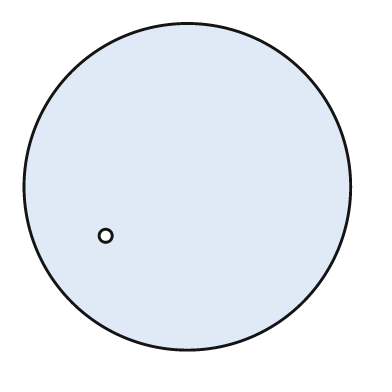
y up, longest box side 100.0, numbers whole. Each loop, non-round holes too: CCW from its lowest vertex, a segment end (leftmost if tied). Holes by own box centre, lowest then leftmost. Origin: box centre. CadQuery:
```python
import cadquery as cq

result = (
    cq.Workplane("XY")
    .moveTo(0.0, 0.0)
    .circle(50.0)
    .moveTo(-25.0, -15.0)
    .circle(2.0)
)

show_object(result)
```